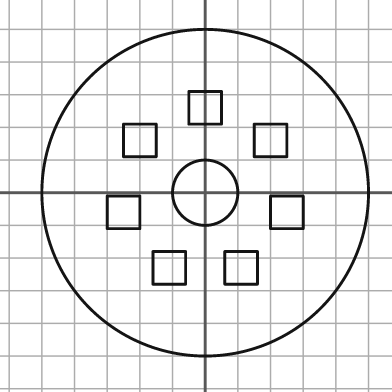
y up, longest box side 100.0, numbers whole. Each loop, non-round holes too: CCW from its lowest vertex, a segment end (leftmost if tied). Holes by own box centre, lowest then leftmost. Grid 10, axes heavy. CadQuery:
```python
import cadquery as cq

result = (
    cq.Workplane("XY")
    .moveTo(0.0, 0.0)
    .circle(50.0)
    .moveTo(-16.0, -28.0)
    .lineTo(-6.0, -28.0)
    .lineTo(-6.0, -18.0)
    .lineTo(-16.0, -18.0)
    .close()
    .moveTo(6.0, -28.0)
    .lineTo(16.0, -28.0)
    .lineTo(16.0, -18.0)
    .lineTo(6.0, -18.0)
    .close()
    .moveTo(-30.0, -11.0)
    .lineTo(-20.0, -11.0)
    .lineTo(-20.0, -1.0)
    .lineTo(-30.0, -1.0)
    .close()
    .moveTo(20.0, -11.0)
    .lineTo(30.0, -11.0)
    .lineTo(30.0, -1.0)
    .lineTo(20.0, -1.0)
    .close()
    .moveTo(0.0, 0.0)
    .circle(10.0)
    .moveTo(-25.0, 11.0)
    .lineTo(-15.0, 11.0)
    .lineTo(-15.0, 21.0)
    .lineTo(-25.0, 21.0)
    .close()
    .moveTo(15.0, 11.0)
    .lineTo(25.0, 11.0)
    .lineTo(25.0, 21.0)
    .lineTo(15.0, 21.0)
    .close()
    .moveTo(-5.0, 21.0)
    .lineTo(5.0, 21.0)
    .lineTo(5.0, 31.0)
    .lineTo(-5.0, 31.0)
    .close()
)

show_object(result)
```